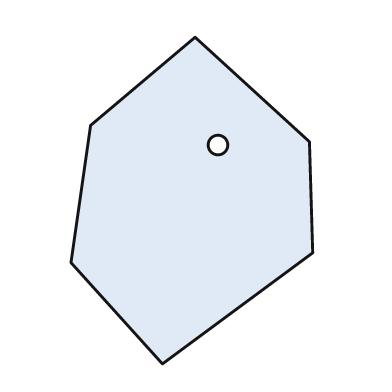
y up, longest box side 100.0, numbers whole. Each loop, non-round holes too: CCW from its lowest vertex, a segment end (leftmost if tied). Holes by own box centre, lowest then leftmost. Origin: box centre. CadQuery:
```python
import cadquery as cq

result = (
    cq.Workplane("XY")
    .moveTo(-9.0, -50.0)
    .lineTo(37.0, -16.0)
    .lineTo(36.0, 18.0)
    .lineTo(1.0, 50.0)
    .lineTo(-31.0, 23.0)
    .lineTo(-37.0, -19.0)
    .close()
    .moveTo(8.0, 17.0)
    .circle(3.0)
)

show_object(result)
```